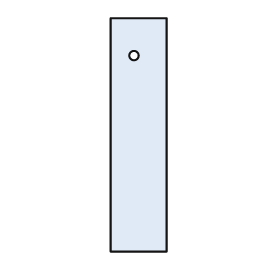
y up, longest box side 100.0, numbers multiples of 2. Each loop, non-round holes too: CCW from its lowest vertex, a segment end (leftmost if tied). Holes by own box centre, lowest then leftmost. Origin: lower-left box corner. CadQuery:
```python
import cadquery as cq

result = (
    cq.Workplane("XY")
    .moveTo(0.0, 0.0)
    .lineTo(24.0, 0.0)
    .lineTo(24.0, 100.0)
    .lineTo(0.0, 100.0)
    .close()
    .moveTo(10.0, 84.0)
    .circle(2.0)
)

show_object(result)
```